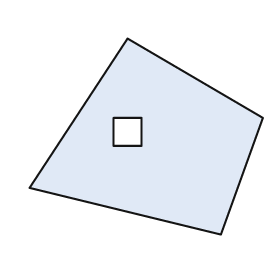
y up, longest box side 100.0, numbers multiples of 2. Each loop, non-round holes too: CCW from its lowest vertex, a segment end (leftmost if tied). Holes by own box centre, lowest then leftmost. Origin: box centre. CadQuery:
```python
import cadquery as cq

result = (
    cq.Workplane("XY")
    .moveTo(32.0, -42.0)
    .lineTo(50.0, 8.0)
    .lineTo(-8.0, 42.0)
    .lineTo(-50.0, -22.0)
    .close()
    .moveTo(-14.0, -4.0)
    .lineTo(-2.0, -4.0)
    .lineTo(-2.0, 8.0)
    .lineTo(-14.0, 8.0)
    .close()
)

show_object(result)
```